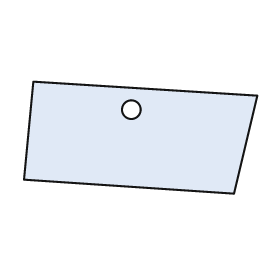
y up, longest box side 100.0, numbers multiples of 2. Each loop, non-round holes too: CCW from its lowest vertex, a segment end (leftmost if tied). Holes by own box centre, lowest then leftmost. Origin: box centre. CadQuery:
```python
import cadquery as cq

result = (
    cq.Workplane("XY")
    .moveTo(40.0, -24.0)
    .lineTo(50.0, 18.0)
    .lineTo(-46.0, 24.0)
    .lineTo(-50.0, -18.0)
    .close()
    .moveTo(-4.0, 12.0)
    .circle(4.0)
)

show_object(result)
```